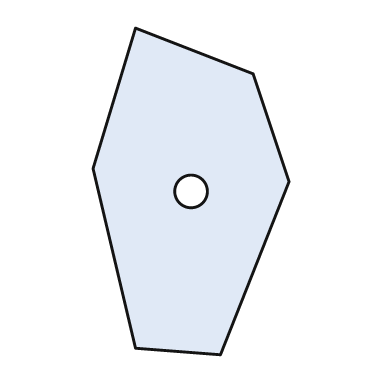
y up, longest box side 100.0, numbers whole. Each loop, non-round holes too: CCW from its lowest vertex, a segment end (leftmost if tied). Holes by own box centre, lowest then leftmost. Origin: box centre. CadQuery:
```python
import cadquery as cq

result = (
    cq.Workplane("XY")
    .moveTo(9.0, -50.0)
    .lineTo(30.0, 3.0)
    .lineTo(19.0, 36.0)
    .lineTo(-17.0, 50.0)
    .lineTo(-30.0, 7.0)
    .lineTo(-17.0, -48.0)
    .close()
    .moveTo(0.0, 0.0)
    .circle(5.0)
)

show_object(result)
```